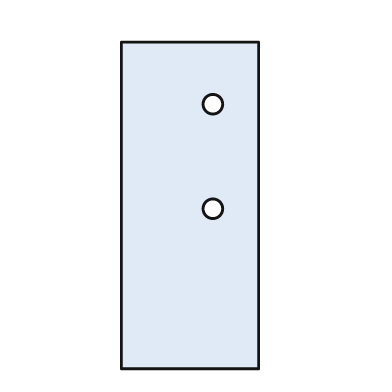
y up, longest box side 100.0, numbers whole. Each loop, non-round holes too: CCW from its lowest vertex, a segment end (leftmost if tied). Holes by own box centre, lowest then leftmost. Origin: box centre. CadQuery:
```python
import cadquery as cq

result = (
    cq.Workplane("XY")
    .moveTo(-21.0, -50.0)
    .lineTo(21.0, -50.0)
    .lineTo(21.0, 50.0)
    .lineTo(-21.0, 50.0)
    .close()
    .moveTo(7.0, -1.0)
    .circle(3.0)
    .moveTo(7.0, 31.0)
    .circle(3.0)
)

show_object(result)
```